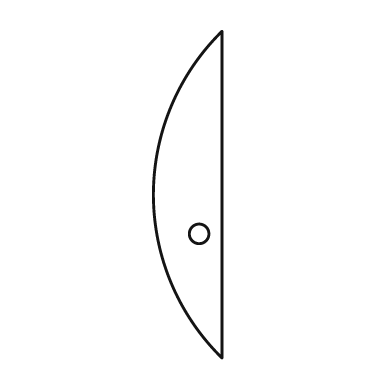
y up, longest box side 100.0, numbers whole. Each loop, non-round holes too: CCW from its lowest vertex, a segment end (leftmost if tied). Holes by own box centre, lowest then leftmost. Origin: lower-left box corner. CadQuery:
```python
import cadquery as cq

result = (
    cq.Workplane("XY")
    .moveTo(21.0, 0.0)
    .lineTo(21.0, 100.0)
    .threePointArc((0.0, 50.0), (21.0, 0.0))
    .close()
    .moveTo(14.0, 38.0)
    .circle(3.0)
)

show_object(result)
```